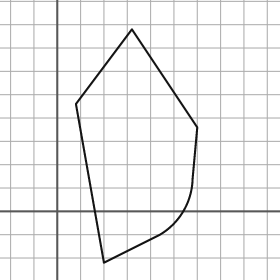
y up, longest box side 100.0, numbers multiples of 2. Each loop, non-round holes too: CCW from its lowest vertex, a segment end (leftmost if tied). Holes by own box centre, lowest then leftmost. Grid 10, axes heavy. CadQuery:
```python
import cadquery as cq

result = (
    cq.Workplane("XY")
    .moveTo(20.0, -22.0)
    .lineTo(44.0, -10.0)
    .threePointArc((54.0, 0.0), (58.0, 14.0))
    .lineTo(60.0, 36.0)
    .lineTo(32.0, 78.0)
    .lineTo(8.0, 46.0)
    .close()
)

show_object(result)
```